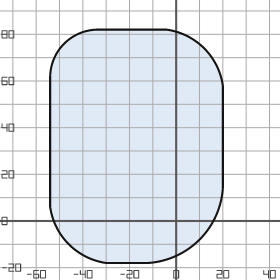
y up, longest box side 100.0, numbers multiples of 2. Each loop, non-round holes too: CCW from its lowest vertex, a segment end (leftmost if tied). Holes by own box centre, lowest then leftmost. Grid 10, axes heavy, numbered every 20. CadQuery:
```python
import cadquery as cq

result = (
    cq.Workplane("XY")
    .moveTo(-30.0, -18.0)
    .lineTo(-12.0, -18.0)
    .threePointArc((10.0, -8.0), (20.0, 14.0))
    .lineTo(20.0, 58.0)
    .threePointArc((12.0, 74.0), (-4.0, 82.0))
    .lineTo(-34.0, 82.0)
    .threePointArc((-48.0, 76.0), (-54.0, 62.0))
    .lineTo(-54.0, 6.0)
    .threePointArc((-46.0, -10.0), (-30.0, -18.0))
    .close()
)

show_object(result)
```